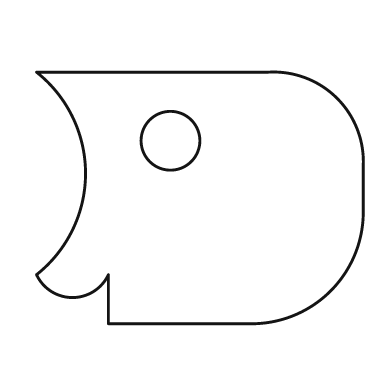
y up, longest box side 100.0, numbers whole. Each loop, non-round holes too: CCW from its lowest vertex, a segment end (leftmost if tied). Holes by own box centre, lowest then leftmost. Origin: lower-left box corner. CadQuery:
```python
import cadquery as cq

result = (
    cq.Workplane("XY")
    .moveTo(22.0, 0.0)
    .lineTo(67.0, 0.0)
    .threePointArc((90.0, 10.0), (100.0, 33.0))
    .lineTo(100.0, 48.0)
    .threePointArc((92.0, 69.0), (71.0, 77.0))
    .lineTo(0.0, 77.0)
    .threePointArc((15.0, 46.0), (0.0, 15.0))
    .threePointArc((11.0, 8.0), (22.0, 15.0))
    .close()
    .moveTo(41.0, 56.0)
    .circle(9.0)
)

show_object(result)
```